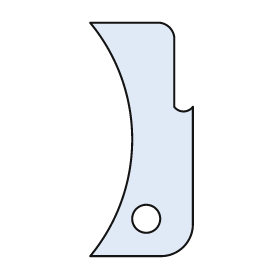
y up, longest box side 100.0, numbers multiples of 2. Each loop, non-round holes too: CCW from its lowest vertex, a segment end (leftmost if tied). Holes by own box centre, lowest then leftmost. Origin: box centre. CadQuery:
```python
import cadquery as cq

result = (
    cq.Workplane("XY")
    .moveTo(-22.0, -50.0)
    .lineTo(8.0, -50.0)
    .threePointArc((18.0, -46.0), (22.0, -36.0))
    .lineTo(22.0, 14.0)
    .threePointArc((18.0, 12.0), (14.0, 14.0))
    .lineTo(14.0, 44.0)
    .threePointArc((12.0, 48.0), (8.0, 50.0))
    .lineTo(-22.0, 50.0)
    .threePointArc((-4.0, 0.0), (-22.0, -50.0))
    .close()
    .moveTo(2.0, -34.0)
    .circle(6.0)
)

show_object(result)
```